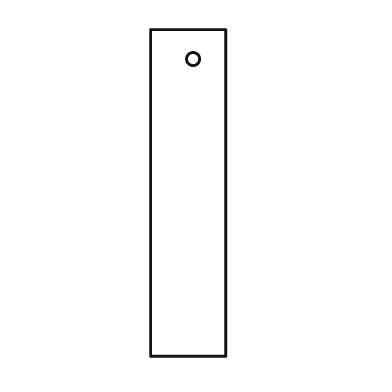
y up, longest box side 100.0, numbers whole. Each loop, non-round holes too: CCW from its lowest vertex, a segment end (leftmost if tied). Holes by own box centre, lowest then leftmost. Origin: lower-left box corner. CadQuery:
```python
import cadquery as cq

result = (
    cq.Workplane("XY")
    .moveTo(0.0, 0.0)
    .lineTo(23.0, 0.0)
    .lineTo(23.0, 100.0)
    .lineTo(0.0, 100.0)
    .close()
    .moveTo(13.0, 91.0)
    .circle(2.0)
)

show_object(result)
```